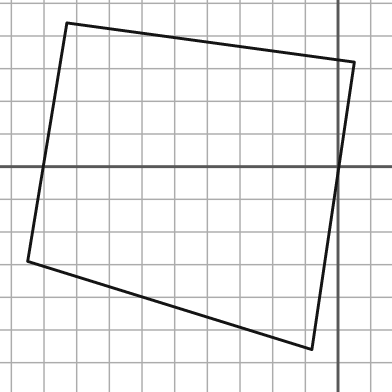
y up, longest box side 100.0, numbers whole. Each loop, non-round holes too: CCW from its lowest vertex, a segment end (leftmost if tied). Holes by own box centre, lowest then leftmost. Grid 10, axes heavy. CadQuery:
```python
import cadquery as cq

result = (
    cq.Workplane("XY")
    .moveTo(-8.0, -56.0)
    .lineTo(5.0, 32.0)
    .lineTo(-83.0, 44.0)
    .lineTo(-95.0, -29.0)
    .close()
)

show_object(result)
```